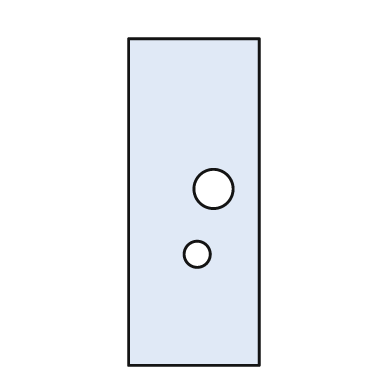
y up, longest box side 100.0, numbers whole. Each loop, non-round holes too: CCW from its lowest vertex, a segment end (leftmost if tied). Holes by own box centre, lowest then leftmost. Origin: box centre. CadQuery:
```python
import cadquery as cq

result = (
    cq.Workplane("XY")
    .moveTo(-20.0, -50.0)
    .lineTo(20.0, -50.0)
    .lineTo(20.0, 50.0)
    .lineTo(-20.0, 50.0)
    .close()
    .moveTo(1.0, -16.0)
    .circle(4.0)
    .moveTo(6.0, 4.0)
    .circle(6.0)
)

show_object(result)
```